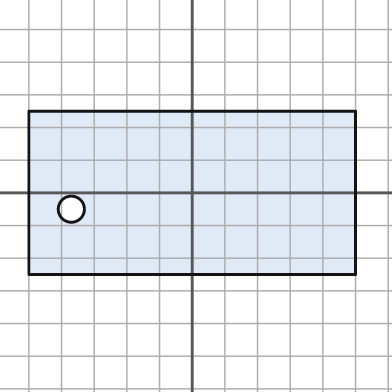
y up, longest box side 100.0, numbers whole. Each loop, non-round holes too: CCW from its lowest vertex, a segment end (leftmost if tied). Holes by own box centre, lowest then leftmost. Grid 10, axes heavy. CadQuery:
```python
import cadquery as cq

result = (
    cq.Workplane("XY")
    .moveTo(-50.0, -25.0)
    .lineTo(50.0, -25.0)
    .lineTo(50.0, 25.0)
    .lineTo(-50.0, 25.0)
    .close()
    .moveTo(-37.0, -5.0)
    .circle(4.0)
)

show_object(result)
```